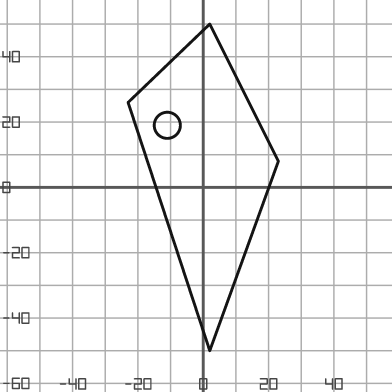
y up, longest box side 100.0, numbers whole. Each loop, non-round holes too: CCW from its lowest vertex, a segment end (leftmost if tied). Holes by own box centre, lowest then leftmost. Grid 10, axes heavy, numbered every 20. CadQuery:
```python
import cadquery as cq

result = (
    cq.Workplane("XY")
    .moveTo(2.0, -50.0)
    .lineTo(23.0, 8.0)
    .lineTo(2.0, 50.0)
    .lineTo(-23.0, 26.0)
    .close()
    .moveTo(-11.0, 19.0)
    .circle(4.0)
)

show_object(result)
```